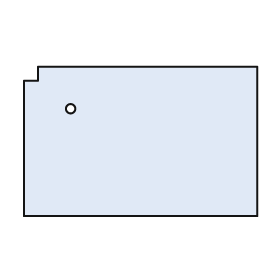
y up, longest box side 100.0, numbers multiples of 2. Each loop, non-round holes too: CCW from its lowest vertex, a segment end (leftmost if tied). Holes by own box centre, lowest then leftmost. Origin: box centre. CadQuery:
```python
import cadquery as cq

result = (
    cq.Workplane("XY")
    .moveTo(-50.0, -32.0)
    .lineTo(50.0, -32.0)
    .lineTo(50.0, 32.0)
    .lineTo(-44.0, 32.0)
    .lineTo(-44.0, 26.0)
    .lineTo(-50.0, 26.0)
    .close()
    .moveTo(-30.0, 14.0)
    .circle(2.0)
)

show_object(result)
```